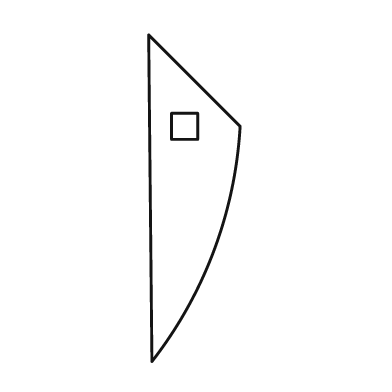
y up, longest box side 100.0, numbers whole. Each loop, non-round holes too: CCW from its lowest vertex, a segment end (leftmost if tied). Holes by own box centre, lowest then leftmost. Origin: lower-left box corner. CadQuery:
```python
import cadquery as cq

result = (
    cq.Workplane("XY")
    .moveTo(1.0, 0.0)
    .threePointArc((20.0, 34.0), (28.0, 72.0))
    .lineTo(0.0, 100.0)
    .close()
    .moveTo(7.0, 68.0)
    .lineTo(15.0, 68.0)
    .lineTo(15.0, 76.0)
    .lineTo(7.0, 76.0)
    .close()
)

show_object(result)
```